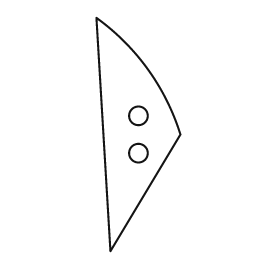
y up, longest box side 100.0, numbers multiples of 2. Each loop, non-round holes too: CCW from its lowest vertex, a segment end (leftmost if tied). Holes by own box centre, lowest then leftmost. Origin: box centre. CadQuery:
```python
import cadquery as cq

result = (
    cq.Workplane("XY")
    .moveTo(-12.0, -50.0)
    .lineTo(18.0, 0.0)
    .threePointArc((4.0, 28.0), (-18.0, 50.0))
    .close()
    .moveTo(0.0, -8.0)
    .circle(4.0)
    .moveTo(0.0, 8.0)
    .circle(4.0)
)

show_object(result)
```